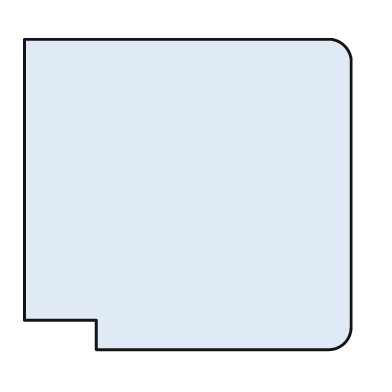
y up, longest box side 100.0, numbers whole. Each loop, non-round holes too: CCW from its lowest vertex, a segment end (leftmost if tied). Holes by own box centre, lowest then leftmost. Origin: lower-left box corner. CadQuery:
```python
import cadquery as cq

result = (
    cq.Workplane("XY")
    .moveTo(22.0, 0.0)
    .lineTo(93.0, 0.0)
    .threePointArc((98.0, 2.0), (100.0, 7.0))
    .lineTo(100.0, 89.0)
    .threePointArc((98.0, 93.0), (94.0, 95.0))
    .lineTo(0.0, 95.0)
    .lineTo(0.0, 9.0)
    .lineTo(22.0, 9.0)
    .close()
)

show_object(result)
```